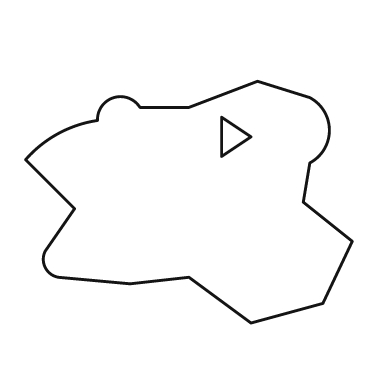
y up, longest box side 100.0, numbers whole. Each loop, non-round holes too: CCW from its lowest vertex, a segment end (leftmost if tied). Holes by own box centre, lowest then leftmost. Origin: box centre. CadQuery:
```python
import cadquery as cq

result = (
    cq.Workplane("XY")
    .moveTo(19.0, -37.0)
    .lineTo(41.0, -31.0)
    .lineTo(50.0, -12.0)
    .lineTo(35.0, 0.0)
    .lineTo(37.0, 12.0)
    .threePointArc((43.0, 22.0), (37.0, 32.0))
    .lineTo(21.0, 37.0)
    .lineTo(0.0, 29.0)
    .lineTo(-15.0, 29.0)
    .threePointArc((-23.0, 32.0), (-28.0, 25.0))
    .threePointArc((-40.0, 21.0), (-50.0, 13.0))
    .lineTo(-35.0, -2.0)
    .lineTo(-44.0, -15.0)
    .threePointArc((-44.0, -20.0), (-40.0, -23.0))
    .lineTo(-18.0, -25.0)
    .lineTo(0.0, -23.0)
    .close()
    .moveTo(10.0, 14.0)
    .lineTo(19.0, 20.0)
    .lineTo(10.0, 26.0)
    .close()
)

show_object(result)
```